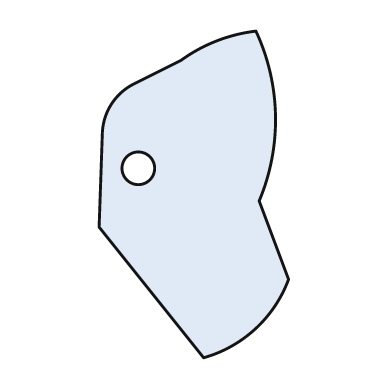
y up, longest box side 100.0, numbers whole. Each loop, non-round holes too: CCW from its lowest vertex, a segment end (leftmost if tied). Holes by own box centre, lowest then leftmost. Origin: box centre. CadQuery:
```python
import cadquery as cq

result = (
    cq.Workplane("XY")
    .moveTo(3.0, -50.0)
    .threePointArc((19.0, -41.0), (29.0, -26.0))
    .lineTo(20.0, -2.0)
    .threePointArc((25.0, 24.0), (19.0, 50.0))
    .threePointArc((7.0, 47.0), (-4.0, 41.0))
    .lineTo(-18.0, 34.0)
    .threePointArc((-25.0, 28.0), (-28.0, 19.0))
    .lineTo(-29.0, -10.0)
    .close()
    .moveTo(-17.0, 8.0)
    .circle(5.0)
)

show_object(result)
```